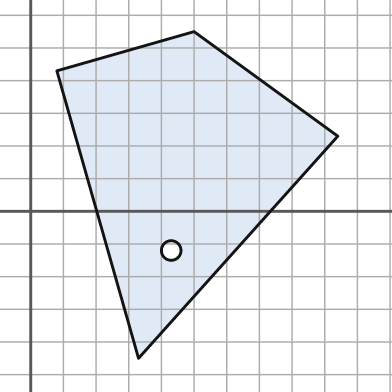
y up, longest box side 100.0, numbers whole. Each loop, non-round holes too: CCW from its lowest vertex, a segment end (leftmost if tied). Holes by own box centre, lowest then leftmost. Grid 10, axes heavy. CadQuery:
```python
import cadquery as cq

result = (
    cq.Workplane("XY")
    .moveTo(33.0, -45.0)
    .lineTo(94.0, 23.0)
    .lineTo(50.0, 55.0)
    .lineTo(8.0, 43.0)
    .close()
    .moveTo(43.0, -12.0)
    .circle(3.0)
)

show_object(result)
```